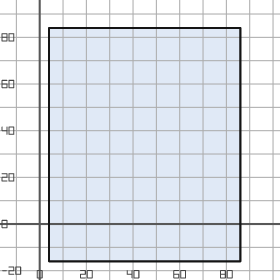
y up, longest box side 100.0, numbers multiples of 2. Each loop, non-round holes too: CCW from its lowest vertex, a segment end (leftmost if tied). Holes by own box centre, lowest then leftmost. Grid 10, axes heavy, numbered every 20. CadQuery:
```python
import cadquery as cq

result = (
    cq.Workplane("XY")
    .moveTo(4.0, -16.0)
    .lineTo(86.0, -16.0)
    .lineTo(86.0, 84.0)
    .lineTo(4.0, 84.0)
    .close()
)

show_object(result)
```